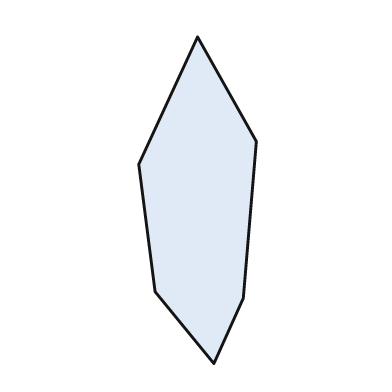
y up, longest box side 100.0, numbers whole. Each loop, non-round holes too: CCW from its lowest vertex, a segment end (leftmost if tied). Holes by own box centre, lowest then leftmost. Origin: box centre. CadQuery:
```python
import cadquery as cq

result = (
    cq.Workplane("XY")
    .moveTo(5.0, -50.0)
    .lineTo(14.0, -30.0)
    .lineTo(18.0, 18.0)
    .lineTo(0.0, 50.0)
    .lineTo(-18.0, 11.0)
    .lineTo(-13.0, -28.0)
    .close()
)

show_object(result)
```